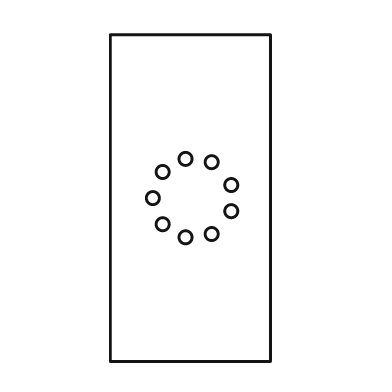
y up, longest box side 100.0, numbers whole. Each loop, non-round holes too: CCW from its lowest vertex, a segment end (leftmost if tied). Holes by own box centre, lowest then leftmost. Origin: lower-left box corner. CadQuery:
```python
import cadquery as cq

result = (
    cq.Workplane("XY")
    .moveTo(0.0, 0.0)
    .lineTo(49.0, 0.0)
    .lineTo(49.0, 100.0)
    .lineTo(0.0, 100.0)
    .close()
    .moveTo(23.0, 38.0)
    .circle(2.0)
    .moveTo(31.0, 39.0)
    .circle(2.0)
    .moveTo(16.0, 42.0)
    .circle(2.0)
    .moveTo(37.0, 46.0)
    .circle(2.0)
    .moveTo(13.0, 50.0)
    .circle(2.0)
    .moveTo(37.0, 54.0)
    .circle(2.0)
    .moveTo(16.0, 58.0)
    .circle(2.0)
    .moveTo(31.0, 61.0)
    .circle(2.0)
    .moveTo(23.0, 62.0)
    .circle(2.0)
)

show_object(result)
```